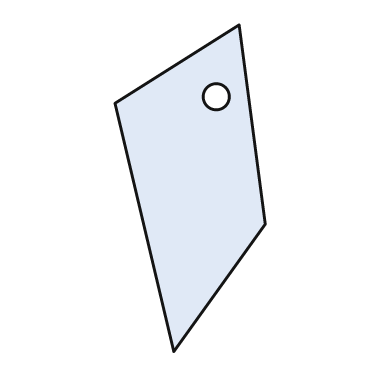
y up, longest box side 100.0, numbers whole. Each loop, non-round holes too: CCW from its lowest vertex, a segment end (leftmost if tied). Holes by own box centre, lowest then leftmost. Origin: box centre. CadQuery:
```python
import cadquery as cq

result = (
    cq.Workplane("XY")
    .moveTo(-5.0, -50.0)
    .lineTo(23.0, -11.0)
    .lineTo(15.0, 50.0)
    .lineTo(-23.0, 26.0)
    .close()
    .moveTo(8.0, 28.0)
    .circle(4.0)
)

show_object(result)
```